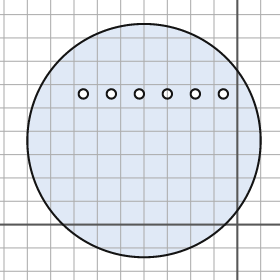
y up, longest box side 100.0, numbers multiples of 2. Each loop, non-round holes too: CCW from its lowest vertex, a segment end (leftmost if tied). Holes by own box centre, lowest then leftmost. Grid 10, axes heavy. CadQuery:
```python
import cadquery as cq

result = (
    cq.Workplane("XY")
    .moveTo(-40.0, 36.0)
    .circle(50.0)
    .moveTo(-66.0, 56.0)
    .circle(2.0)
    .moveTo(-54.0, 56.0)
    .circle(2.0)
    .moveTo(-42.0, 56.0)
    .circle(2.0)
    .moveTo(-30.0, 56.0)
    .circle(2.0)
    .moveTo(-18.0, 56.0)
    .circle(2.0)
    .moveTo(-6.0, 56.0)
    .circle(2.0)
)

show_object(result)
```